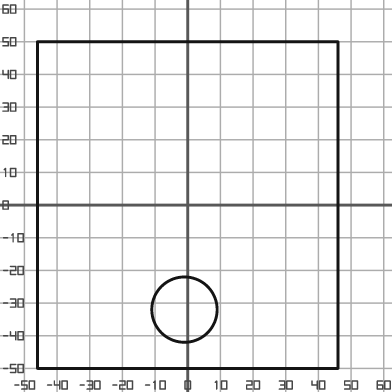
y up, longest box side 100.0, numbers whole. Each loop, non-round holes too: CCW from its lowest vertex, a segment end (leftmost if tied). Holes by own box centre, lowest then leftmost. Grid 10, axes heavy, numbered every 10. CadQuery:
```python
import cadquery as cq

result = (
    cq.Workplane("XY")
    .moveTo(-46.0, -50.0)
    .lineTo(46.0, -50.0)
    .lineTo(46.0, 50.0)
    .lineTo(-46.0, 50.0)
    .close()
    .moveTo(-1.0, -32.0)
    .circle(10.0)
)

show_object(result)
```